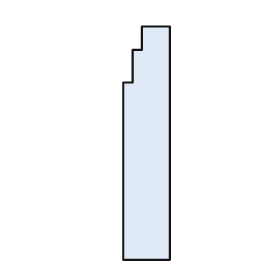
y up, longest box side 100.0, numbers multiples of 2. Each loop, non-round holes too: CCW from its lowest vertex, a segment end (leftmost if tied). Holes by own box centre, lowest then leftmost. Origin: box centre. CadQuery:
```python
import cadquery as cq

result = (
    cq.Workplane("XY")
    .moveTo(-10.0, -50.0)
    .lineTo(10.0, -50.0)
    .lineTo(10.0, 50.0)
    .lineTo(-2.0, 50.0)
    .lineTo(-2.0, 40.0)
    .lineTo(-6.0, 40.0)
    .lineTo(-6.0, 26.0)
    .lineTo(-10.0, 26.0)
    .close()
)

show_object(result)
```